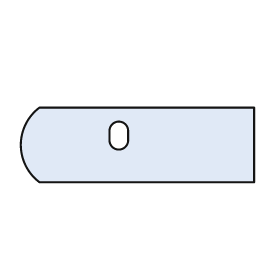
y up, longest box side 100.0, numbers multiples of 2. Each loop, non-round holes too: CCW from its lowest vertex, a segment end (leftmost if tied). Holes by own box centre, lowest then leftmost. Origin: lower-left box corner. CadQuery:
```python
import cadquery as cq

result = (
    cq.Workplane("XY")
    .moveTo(8.0, 0.0)
    .lineTo(100.0, 0.0)
    .lineTo(100.0, 32.0)
    .lineTo(8.0, 32.0)
    .threePointArc((0.0, 16.0), (8.0, 0.0))
    .close()
    .moveTo(38.0, 18.0)
    .threePointArc((42.0, 14.0), (46.0, 18.0))
    .lineTo(46.0, 22.0)
    .threePointArc((42.0, 26.0), (38.0, 22.0))
    .close()
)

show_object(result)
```